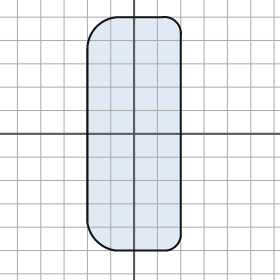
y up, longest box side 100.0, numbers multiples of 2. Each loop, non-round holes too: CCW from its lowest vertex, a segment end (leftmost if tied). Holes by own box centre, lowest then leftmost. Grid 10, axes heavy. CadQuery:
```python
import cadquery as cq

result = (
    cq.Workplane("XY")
    .moveTo(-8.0, -50.0)
    .lineTo(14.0, -50.0)
    .threePointArc((18.0, -48.0), (20.0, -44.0))
    .lineTo(20.0, 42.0)
    .threePointArc((18.0, 48.0), (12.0, 50.0))
    .lineTo(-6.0, 50.0)
    .threePointArc((-16.0, 46.0), (-20.0, 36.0))
    .lineTo(-20.0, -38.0)
    .threePointArc((-16.0, -46.0), (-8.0, -50.0))
    .close()
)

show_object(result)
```